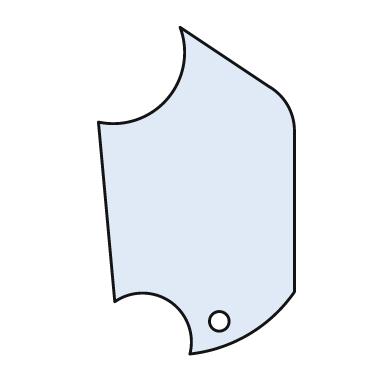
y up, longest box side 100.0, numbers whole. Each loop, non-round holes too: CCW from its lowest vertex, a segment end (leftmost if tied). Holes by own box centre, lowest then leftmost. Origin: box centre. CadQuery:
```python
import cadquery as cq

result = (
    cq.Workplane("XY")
    .moveTo(-2.0, -50.0)
    .threePointArc((16.0, -44.0), (30.0, -31.0))
    .lineTo(30.0, 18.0)
    .threePointArc((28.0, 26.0), (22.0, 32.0))
    .lineTo(-5.0, 50.0)
    .threePointArc((-9.0, 28.0), (-30.0, 21.0))
    .lineTo(-25.0, -34.0)
    .threePointArc((-8.0, -34.0), (-2.0, -50.0))
    .close()
    .moveTo(7.0, -40.0)
    .circle(3.0)
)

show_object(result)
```